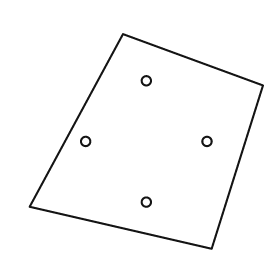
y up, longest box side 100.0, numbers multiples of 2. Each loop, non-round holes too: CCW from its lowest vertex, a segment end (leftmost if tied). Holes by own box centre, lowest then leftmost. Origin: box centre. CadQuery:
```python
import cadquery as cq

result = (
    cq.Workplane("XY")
    .moveTo(28.0, -46.0)
    .lineTo(50.0, 24.0)
    .lineTo(-10.0, 46.0)
    .lineTo(-50.0, -28.0)
    .close()
    .moveTo(0.0, -26.0)
    .circle(2.0)
    .moveTo(-26.0, 0.0)
    .circle(2.0)
    .moveTo(26.0, 0.0)
    .circle(2.0)
    .moveTo(0.0, 26.0)
    .circle(2.0)
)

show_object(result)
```